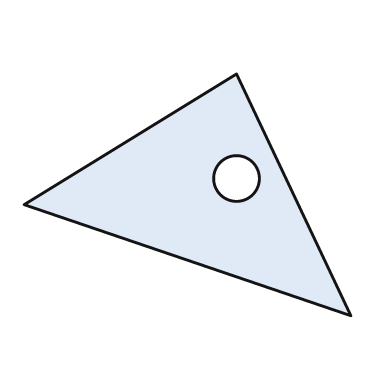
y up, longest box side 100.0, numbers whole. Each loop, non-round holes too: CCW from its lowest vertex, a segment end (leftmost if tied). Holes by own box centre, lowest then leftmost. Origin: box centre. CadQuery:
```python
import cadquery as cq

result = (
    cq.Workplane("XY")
    .moveTo(50.0, -37.0)
    .lineTo(15.0, 37.0)
    .lineTo(-50.0, -3.0)
    .close()
    .moveTo(15.0, 5.0)
    .circle(7.0)
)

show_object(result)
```